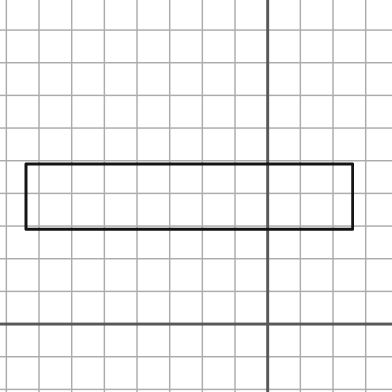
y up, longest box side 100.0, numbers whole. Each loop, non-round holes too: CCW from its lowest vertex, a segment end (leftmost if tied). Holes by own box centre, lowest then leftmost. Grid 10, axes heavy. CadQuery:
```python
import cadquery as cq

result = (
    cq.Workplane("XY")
    .moveTo(-74.0, 29.0)
    .lineTo(26.0, 29.0)
    .lineTo(26.0, 49.0)
    .lineTo(-74.0, 49.0)
    .close()
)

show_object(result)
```